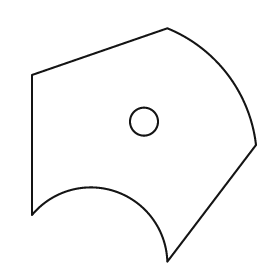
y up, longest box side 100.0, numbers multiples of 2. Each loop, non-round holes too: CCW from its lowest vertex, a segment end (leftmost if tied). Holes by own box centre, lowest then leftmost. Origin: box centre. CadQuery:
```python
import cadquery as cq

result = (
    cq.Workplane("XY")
    .moveTo(10.0, -50.0)
    .lineTo(48.0, 0.0)
    .threePointArc((36.0, 30.0), (10.0, 50.0))
    .lineTo(-48.0, 30.0)
    .lineTo(-48.0, -30.0)
    .threePointArc((-12.0, -20.0), (10.0, -50.0))
    .close()
    .moveTo(0.0, 10.0)
    .circle(6.0)
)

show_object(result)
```